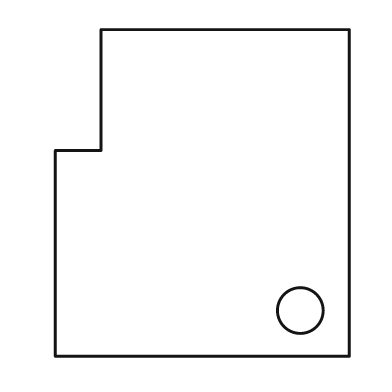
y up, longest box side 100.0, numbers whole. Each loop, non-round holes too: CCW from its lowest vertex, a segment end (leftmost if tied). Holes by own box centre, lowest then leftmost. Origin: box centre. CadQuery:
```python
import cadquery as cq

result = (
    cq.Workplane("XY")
    .moveTo(-45.0, -50.0)
    .lineTo(45.0, -50.0)
    .lineTo(45.0, 50.0)
    .lineTo(-31.0, 50.0)
    .lineTo(-31.0, 13.0)
    .lineTo(-45.0, 13.0)
    .close()
    .moveTo(30.0, -36.0)
    .circle(7.0)
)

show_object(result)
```